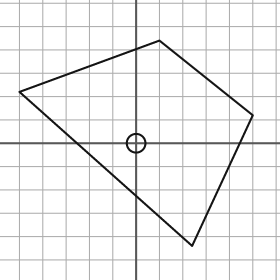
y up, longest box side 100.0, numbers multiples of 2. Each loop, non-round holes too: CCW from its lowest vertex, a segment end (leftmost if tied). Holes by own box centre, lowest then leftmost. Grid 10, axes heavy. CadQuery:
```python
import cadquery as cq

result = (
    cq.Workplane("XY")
    .moveTo(24.0, -44.0)
    .lineTo(50.0, 12.0)
    .lineTo(10.0, 44.0)
    .lineTo(-50.0, 22.0)
    .close()
    .moveTo(0.0, 0.0)
    .circle(4.0)
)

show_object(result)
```